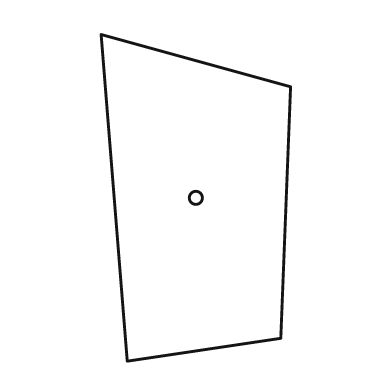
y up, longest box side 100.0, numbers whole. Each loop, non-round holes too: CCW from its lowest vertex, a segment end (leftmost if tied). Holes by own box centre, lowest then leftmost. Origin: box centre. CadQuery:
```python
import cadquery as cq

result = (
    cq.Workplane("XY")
    .moveTo(-21.0, -50.0)
    .lineTo(26.0, -43.0)
    .lineTo(29.0, 34.0)
    .lineTo(-29.0, 50.0)
    .close()
    .moveTo(0.0, 0.0)
    .circle(2.0)
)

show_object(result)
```